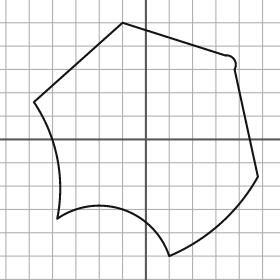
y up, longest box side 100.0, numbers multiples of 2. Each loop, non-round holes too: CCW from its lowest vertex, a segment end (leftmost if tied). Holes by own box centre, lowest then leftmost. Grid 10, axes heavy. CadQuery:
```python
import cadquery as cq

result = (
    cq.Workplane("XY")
    .moveTo(10.0, -50.0)
    .threePointArc((32.0, -36.0), (48.0, -16.0))
    .lineTo(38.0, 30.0)
    .threePointArc((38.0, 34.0), (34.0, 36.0))
    .lineTo(-10.0, 50.0)
    .lineTo(-48.0, 16.0)
    .threePointArc((-38.0, -8.0), (-38.0, -34.0))
    .threePointArc((-10.0, -30.0), (10.0, -50.0))
    .close()
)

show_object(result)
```